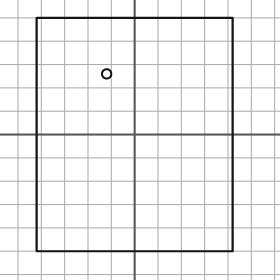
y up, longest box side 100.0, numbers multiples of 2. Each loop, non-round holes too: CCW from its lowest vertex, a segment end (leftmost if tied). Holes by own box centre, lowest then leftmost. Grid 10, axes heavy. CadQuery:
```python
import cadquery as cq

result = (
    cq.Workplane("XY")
    .moveTo(-42.0, -50.0)
    .lineTo(42.0, -50.0)
    .lineTo(42.0, 50.0)
    .lineTo(-42.0, 50.0)
    .close()
    .moveTo(-12.0, 26.0)
    .circle(2.0)
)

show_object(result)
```